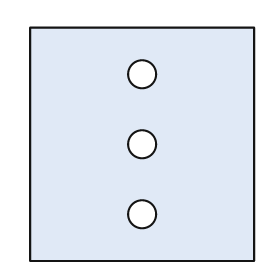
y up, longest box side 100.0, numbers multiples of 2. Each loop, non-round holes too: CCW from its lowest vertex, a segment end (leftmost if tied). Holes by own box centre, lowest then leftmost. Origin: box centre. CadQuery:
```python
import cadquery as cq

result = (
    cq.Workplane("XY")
    .moveTo(-48.0, -50.0)
    .lineTo(48.0, -50.0)
    .lineTo(48.0, 50.0)
    .lineTo(-48.0, 50.0)
    .close()
    .moveTo(0.0, -30.0)
    .circle(6.0)
    .moveTo(0.0, 0.0)
    .circle(6.0)
    .moveTo(0.0, 30.0)
    .circle(6.0)
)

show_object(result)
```